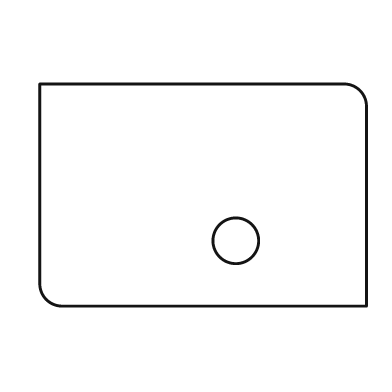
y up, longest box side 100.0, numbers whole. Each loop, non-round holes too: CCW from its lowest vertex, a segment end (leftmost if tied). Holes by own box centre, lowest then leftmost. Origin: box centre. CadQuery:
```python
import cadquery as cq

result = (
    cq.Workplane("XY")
    .moveTo(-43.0, -34.0)
    .lineTo(50.0, -34.0)
    .lineTo(50.0, 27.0)
    .threePointArc((48.0, 32.0), (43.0, 34.0))
    .lineTo(-50.0, 34.0)
    .lineTo(-50.0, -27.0)
    .threePointArc((-48.0, -32.0), (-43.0, -34.0))
    .close()
    .moveTo(10.0, -14.0)
    .circle(7.0)
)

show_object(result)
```